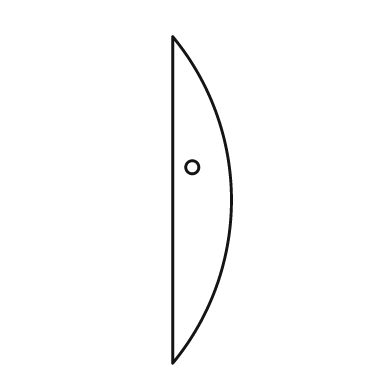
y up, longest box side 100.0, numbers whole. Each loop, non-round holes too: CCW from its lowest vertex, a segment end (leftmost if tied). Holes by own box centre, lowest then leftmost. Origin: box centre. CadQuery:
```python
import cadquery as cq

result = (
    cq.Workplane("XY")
    .moveTo(-9.0, -50.0)
    .threePointArc((9.0, 0.0), (-9.0, 50.0))
    .close()
    .moveTo(-3.0, 10.0)
    .circle(2.0)
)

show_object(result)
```